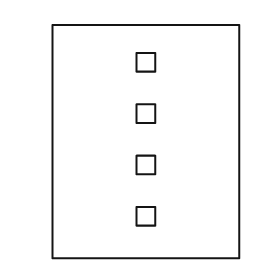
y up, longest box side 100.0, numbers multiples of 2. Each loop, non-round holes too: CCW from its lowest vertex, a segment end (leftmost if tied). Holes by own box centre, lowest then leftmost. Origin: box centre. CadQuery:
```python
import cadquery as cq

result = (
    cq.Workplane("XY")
    .moveTo(-40.0, -50.0)
    .lineTo(40.0, -50.0)
    .lineTo(40.0, 50.0)
    .lineTo(-40.0, 50.0)
    .close()
    .moveTo(-4.0, -36.0)
    .lineTo(4.0, -36.0)
    .lineTo(4.0, -28.0)
    .lineTo(-4.0, -28.0)
    .close()
    .moveTo(-4.0, -14.0)
    .lineTo(4.0, -14.0)
    .lineTo(4.0, -6.0)
    .lineTo(-4.0, -6.0)
    .close()
    .moveTo(-4.0, 8.0)
    .lineTo(4.0, 8.0)
    .lineTo(4.0, 16.0)
    .lineTo(-4.0, 16.0)
    .close()
    .moveTo(-4.0, 30.0)
    .lineTo(4.0, 30.0)
    .lineTo(4.0, 38.0)
    .lineTo(-4.0, 38.0)
    .close()
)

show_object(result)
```